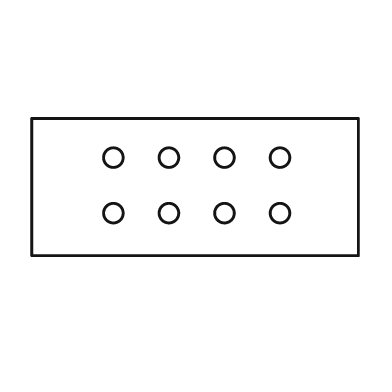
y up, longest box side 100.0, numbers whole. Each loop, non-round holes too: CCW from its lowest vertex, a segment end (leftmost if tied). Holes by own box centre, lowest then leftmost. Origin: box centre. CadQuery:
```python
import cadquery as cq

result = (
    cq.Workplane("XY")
    .moveTo(-50.0, -21.0)
    .lineTo(50.0, -21.0)
    .lineTo(50.0, 21.0)
    .lineTo(-50.0, 21.0)
    .close()
    .moveTo(-25.0, -8.0)
    .circle(3.0)
    .moveTo(-8.0, -8.0)
    .circle(3.0)
    .moveTo(9.0, -8.0)
    .circle(3.0)
    .moveTo(26.0, -8.0)
    .circle(3.0)
    .moveTo(-25.0, 9.0)
    .circle(3.0)
    .moveTo(-8.0, 9.0)
    .circle(3.0)
    .moveTo(9.0, 9.0)
    .circle(3.0)
    .moveTo(26.0, 9.0)
    .circle(3.0)
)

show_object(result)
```